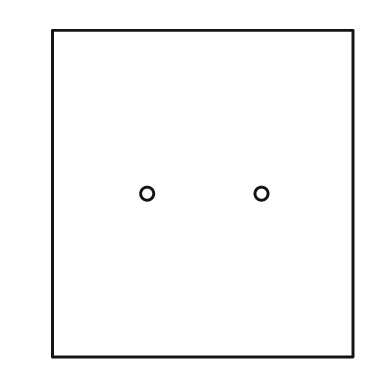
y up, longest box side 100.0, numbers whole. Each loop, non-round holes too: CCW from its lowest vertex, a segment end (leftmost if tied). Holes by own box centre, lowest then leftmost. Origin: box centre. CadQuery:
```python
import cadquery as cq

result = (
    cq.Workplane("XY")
    .moveTo(-46.0, -50.0)
    .lineTo(46.0, -50.0)
    .lineTo(46.0, 50.0)
    .lineTo(-46.0, 50.0)
    .close()
    .moveTo(-17.0, 0.0)
    .circle(2.0)
    .moveTo(18.0, 0.0)
    .circle(2.0)
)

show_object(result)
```